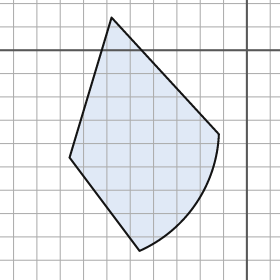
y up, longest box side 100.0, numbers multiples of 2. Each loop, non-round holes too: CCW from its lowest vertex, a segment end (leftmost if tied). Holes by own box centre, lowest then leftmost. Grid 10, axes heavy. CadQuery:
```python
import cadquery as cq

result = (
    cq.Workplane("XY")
    .moveTo(-46.0, -86.0)
    .threePointArc((-22.0, -66.0), (-12.0, -36.0))
    .lineTo(-58.0, 14.0)
    .lineTo(-76.0, -46.0)
    .close()
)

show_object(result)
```